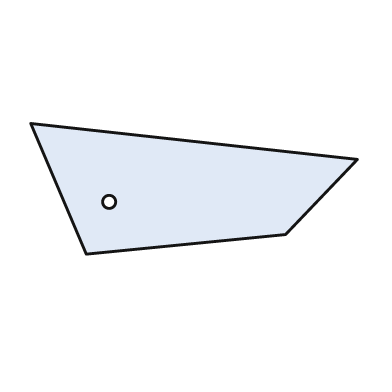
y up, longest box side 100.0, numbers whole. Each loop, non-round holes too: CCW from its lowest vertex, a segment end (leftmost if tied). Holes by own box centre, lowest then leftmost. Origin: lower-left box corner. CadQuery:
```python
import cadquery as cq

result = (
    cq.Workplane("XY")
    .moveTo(17.0, 0.0)
    .lineTo(78.0, 6.0)
    .lineTo(100.0, 29.0)
    .lineTo(0.0, 40.0)
    .close()
    .moveTo(24.0, 16.0)
    .circle(2.0)
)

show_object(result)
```